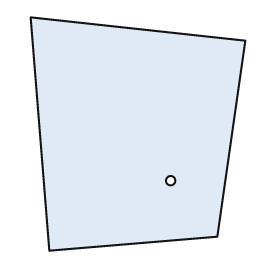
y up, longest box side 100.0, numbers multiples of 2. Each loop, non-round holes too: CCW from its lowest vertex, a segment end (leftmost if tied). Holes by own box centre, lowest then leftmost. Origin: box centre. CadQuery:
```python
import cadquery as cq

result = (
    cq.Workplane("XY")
    .moveTo(-38.0, -50.0)
    .lineTo(34.0, -44.0)
    .lineTo(46.0, 40.0)
    .lineTo(-46.0, 50.0)
    .close()
    .moveTo(14.0, -20.0)
    .circle(2.0)
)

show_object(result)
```